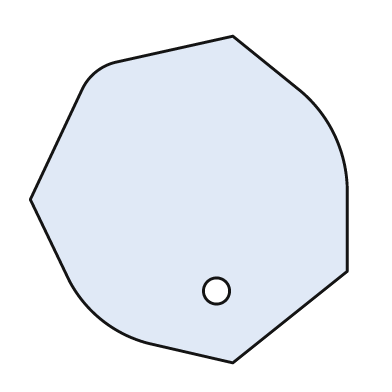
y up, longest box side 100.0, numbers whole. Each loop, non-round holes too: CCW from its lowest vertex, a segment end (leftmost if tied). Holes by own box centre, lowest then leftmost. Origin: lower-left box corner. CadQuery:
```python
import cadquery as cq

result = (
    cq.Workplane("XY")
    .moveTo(62.0, 0.0)
    .lineTo(97.0, 28.0)
    .lineTo(97.0, 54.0)
    .threePointArc((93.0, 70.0), (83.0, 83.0))
    .lineTo(62.0, 100.0)
    .lineTo(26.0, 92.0)
    .threePointArc((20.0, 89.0), (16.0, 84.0))
    .lineTo(0.0, 50.0)
    .lineTo(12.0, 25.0)
    .threePointArc((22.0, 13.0), (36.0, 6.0))
    .close()
    .moveTo(57.0, 22.0)
    .circle(4.0)
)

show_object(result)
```